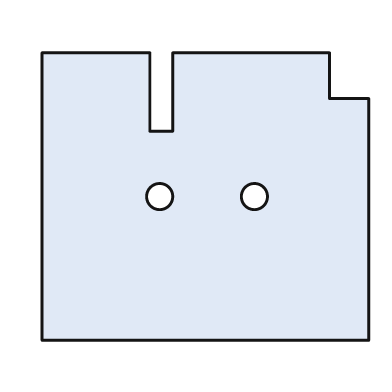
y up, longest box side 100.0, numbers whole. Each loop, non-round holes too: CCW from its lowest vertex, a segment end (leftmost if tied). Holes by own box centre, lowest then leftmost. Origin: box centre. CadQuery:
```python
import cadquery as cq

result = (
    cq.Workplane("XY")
    .moveTo(-50.0, -44.0)
    .lineTo(50.0, -44.0)
    .lineTo(50.0, 30.0)
    .lineTo(38.0, 30.0)
    .lineTo(38.0, 44.0)
    .lineTo(-10.0, 44.0)
    .lineTo(-10.0, 20.0)
    .lineTo(-17.0, 20.0)
    .lineTo(-17.0, 44.0)
    .lineTo(-50.0, 44.0)
    .close()
    .moveTo(-14.0, 0.0)
    .circle(4.0)
    .moveTo(15.0, 0.0)
    .circle(4.0)
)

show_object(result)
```